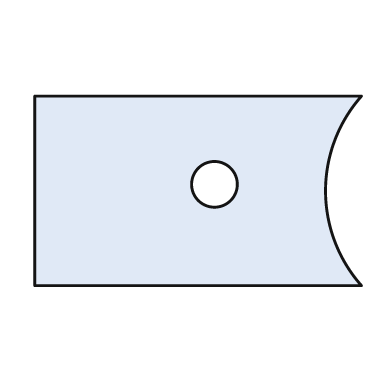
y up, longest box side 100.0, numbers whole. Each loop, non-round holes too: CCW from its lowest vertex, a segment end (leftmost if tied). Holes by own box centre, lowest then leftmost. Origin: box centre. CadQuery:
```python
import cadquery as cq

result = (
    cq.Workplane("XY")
    .moveTo(-50.0, -29.0)
    .lineTo(50.0, -29.0)
    .threePointArc((39.0, 0.0), (50.0, 29.0))
    .lineTo(-50.0, 29.0)
    .close()
    .moveTo(5.0, 2.0)
    .circle(7.0)
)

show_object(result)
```